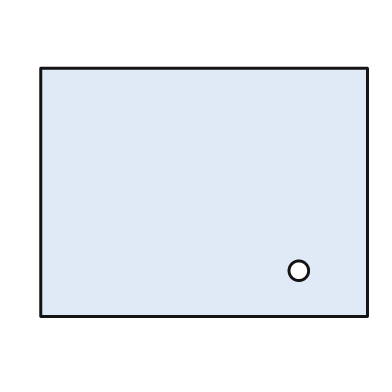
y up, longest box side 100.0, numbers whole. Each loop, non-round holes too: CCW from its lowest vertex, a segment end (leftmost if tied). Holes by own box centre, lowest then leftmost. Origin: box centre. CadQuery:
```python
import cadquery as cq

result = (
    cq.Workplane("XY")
    .moveTo(-50.0, -38.0)
    .lineTo(50.0, -38.0)
    .lineTo(50.0, 38.0)
    .lineTo(-50.0, 38.0)
    .close()
    .moveTo(29.0, -24.0)
    .circle(3.0)
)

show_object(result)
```